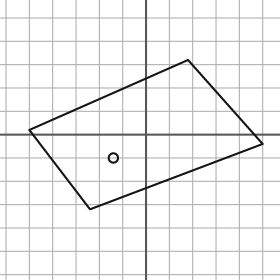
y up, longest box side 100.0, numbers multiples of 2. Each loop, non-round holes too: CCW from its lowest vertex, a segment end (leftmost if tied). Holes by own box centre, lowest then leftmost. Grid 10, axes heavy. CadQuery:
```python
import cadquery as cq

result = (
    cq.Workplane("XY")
    .moveTo(-24.0, -32.0)
    .lineTo(50.0, -4.0)
    .lineTo(18.0, 32.0)
    .lineTo(-50.0, 2.0)
    .close()
    .moveTo(-14.0, -10.0)
    .circle(2.0)
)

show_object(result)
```